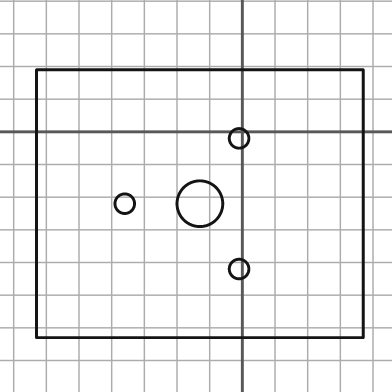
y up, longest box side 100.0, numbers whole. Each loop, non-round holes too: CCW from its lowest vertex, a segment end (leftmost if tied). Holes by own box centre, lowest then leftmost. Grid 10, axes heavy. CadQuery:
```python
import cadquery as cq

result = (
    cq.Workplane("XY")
    .moveTo(-63.0, -63.0)
    .lineTo(37.0, -63.0)
    .lineTo(37.0, 19.0)
    .lineTo(-63.0, 19.0)
    .close()
    .moveTo(-1.0, -42.0)
    .circle(3.0)
    .moveTo(-36.0, -22.0)
    .circle(3.0)
    .moveTo(-13.0, -22.0)
    .circle(7.0)
    .moveTo(-1.0, -2.0)
    .circle(3.0)
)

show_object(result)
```